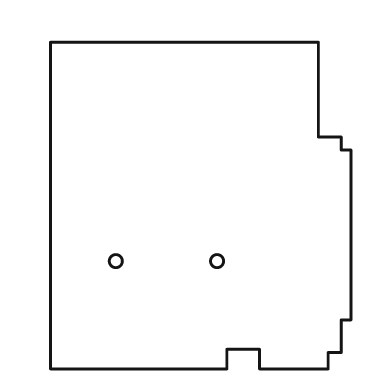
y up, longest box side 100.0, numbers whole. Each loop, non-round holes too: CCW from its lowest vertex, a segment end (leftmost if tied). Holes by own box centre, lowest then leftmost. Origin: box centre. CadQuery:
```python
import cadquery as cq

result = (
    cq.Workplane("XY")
    .moveTo(-46.0, -50.0)
    .lineTo(8.0, -50.0)
    .lineTo(8.0, -44.0)
    .lineTo(18.0, -44.0)
    .lineTo(18.0, -50.0)
    .lineTo(39.0, -50.0)
    .lineTo(39.0, -45.0)
    .lineTo(43.0, -45.0)
    .lineTo(43.0, -35.0)
    .lineTo(46.0, -35.0)
    .lineTo(46.0, 17.0)
    .lineTo(43.0, 17.0)
    .lineTo(43.0, 21.0)
    .lineTo(36.0, 21.0)
    .lineTo(36.0, 50.0)
    .lineTo(-46.0, 50.0)
    .close()
    .moveTo(-26.0, -17.0)
    .circle(2.0)
    .moveTo(5.0, -17.0)
    .circle(2.0)
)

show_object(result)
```